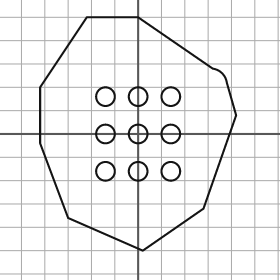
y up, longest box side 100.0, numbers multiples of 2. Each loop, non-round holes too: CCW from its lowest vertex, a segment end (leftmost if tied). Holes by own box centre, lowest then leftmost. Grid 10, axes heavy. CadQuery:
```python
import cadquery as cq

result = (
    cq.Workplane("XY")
    .moveTo(2.0, -50.0)
    .lineTo(28.0, -32.0)
    .lineTo(42.0, 8.0)
    .lineTo(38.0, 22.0)
    .threePointArc((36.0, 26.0), (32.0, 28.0))
    .lineTo(0.0, 50.0)
    .lineTo(-22.0, 50.0)
    .lineTo(-42.0, 20.0)
    .lineTo(-42.0, -4.0)
    .lineTo(-30.0, -36.0)
    .close()
    .moveTo(-14.0, -16.0)
    .circle(4.0)
    .moveTo(0.0, -16.0)
    .circle(4.0)
    .moveTo(14.0, -16.0)
    .circle(4.0)
    .moveTo(-14.0, 0.0)
    .circle(4.0)
    .moveTo(0.0, 0.0)
    .circle(4.0)
    .moveTo(14.0, 0.0)
    .circle(4.0)
    .moveTo(-14.0, 16.0)
    .circle(4.0)
    .moveTo(0.0, 16.0)
    .circle(4.0)
    .moveTo(14.0, 16.0)
    .circle(4.0)
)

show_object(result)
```